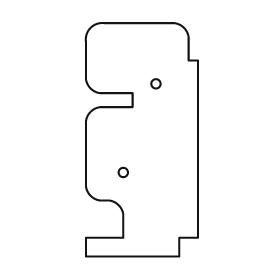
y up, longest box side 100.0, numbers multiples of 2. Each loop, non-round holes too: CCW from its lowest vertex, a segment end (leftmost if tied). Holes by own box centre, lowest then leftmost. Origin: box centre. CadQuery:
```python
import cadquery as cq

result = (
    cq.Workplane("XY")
    .moveTo(-24.0, -50.0)
    .lineTo(16.0, -50.0)
    .lineTo(16.0, -42.0)
    .lineTo(24.0, -42.0)
    .lineTo(24.0, 34.0)
    .lineTo(20.0, 34.0)
    .lineTo(20.0, 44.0)
    .threePointArc((18.0, 48.0), (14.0, 50.0))
    .lineTo(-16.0, 50.0)
    .threePointArc((-22.0, 48.0), (-24.0, 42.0))
    .lineTo(-24.0, 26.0)
    .threePointArc((-22.0, 22.0), (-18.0, 20.0))
    .lineTo(-4.0, 20.0)
    .lineTo(-4.0, 14.0)
    .lineTo(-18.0, 14.0)
    .threePointArc((-22.0, 12.0), (-24.0, 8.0))
    .lineTo(-24.0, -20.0)
    .threePointArc((-22.0, -24.0), (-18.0, -26.0))
    .lineTo(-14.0, -26.0)
    .threePointArc((-10.0, -28.0), (-8.0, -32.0))
    .lineTo(-8.0, -42.0)
    .lineTo(-24.0, -42.0)
    .close()
    .moveTo(-8.0, -14.0)
    .circle(2.0)
    .moveTo(6.0, 24.0)
    .circle(2.0)
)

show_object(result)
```